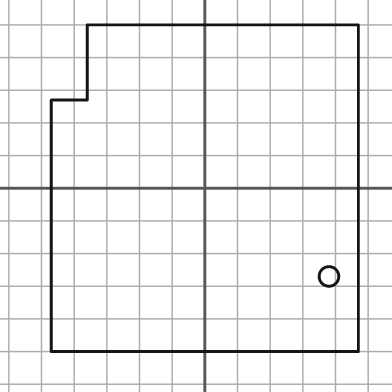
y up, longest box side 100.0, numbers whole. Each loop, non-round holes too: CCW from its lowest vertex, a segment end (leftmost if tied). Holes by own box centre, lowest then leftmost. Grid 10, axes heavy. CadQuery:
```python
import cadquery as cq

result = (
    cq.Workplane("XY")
    .moveTo(-47.0, -50.0)
    .lineTo(47.0, -50.0)
    .lineTo(47.0, 50.0)
    .lineTo(-36.0, 50.0)
    .lineTo(-36.0, 27.0)
    .lineTo(-47.0, 27.0)
    .close()
    .moveTo(38.0, -27.0)
    .circle(3.0)
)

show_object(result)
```